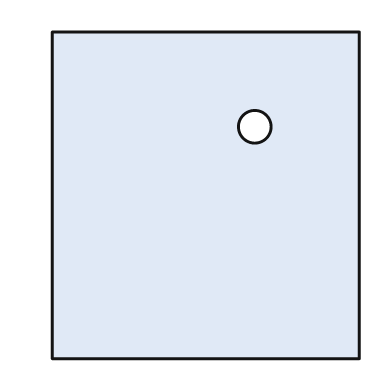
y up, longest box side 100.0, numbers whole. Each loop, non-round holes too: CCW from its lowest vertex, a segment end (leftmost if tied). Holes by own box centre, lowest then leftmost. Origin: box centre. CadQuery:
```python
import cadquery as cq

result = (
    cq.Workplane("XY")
    .moveTo(-47.0, -50.0)
    .lineTo(47.0, -50.0)
    .lineTo(47.0, 50.0)
    .lineTo(-47.0, 50.0)
    .close()
    .moveTo(15.0, 21.0)
    .circle(5.0)
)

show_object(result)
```